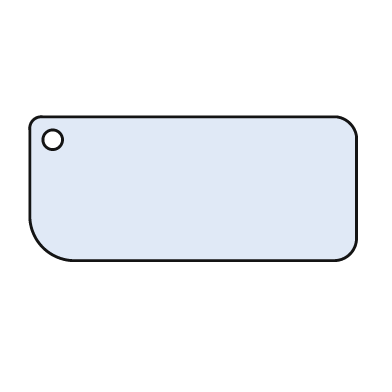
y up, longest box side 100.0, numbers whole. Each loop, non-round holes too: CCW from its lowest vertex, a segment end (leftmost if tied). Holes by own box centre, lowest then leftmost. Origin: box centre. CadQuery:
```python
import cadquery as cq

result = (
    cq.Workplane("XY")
    .moveTo(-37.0, -22.0)
    .lineTo(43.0, -22.0)
    .threePointArc((48.0, -20.0), (50.0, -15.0))
    .lineTo(50.0, 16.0)
    .threePointArc((48.0, 20.0), (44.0, 22.0))
    .lineTo(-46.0, 22.0)
    .threePointArc((-49.0, 21.0), (-50.0, 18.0))
    .lineTo(-50.0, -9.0)
    .threePointArc((-46.0, -18.0), (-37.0, -22.0))
    .close()
    .moveTo(-43.0, 15.0)
    .circle(3.0)
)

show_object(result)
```